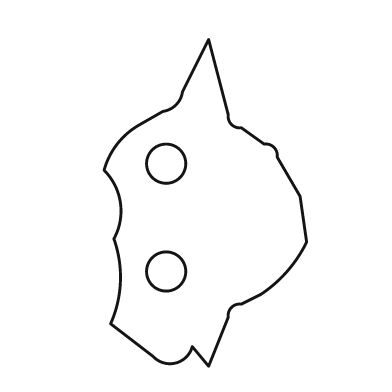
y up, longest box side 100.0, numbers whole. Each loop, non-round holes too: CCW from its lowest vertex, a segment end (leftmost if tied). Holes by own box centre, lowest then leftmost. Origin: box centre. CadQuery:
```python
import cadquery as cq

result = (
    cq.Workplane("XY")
    .moveTo(1.0, -50.0)
    .lineTo(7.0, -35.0)
    .threePointArc((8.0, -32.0), (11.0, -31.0))
    .lineTo(17.0, -28.0)
    .threePointArc((25.0, -21.0), (31.0, -12.0))
    .lineTo(29.0, 2.0)
    .lineTo(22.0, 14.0)
    .threePointArc((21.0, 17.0), (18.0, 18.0))
    .lineTo(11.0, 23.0)
    .threePointArc((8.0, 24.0), (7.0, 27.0))
    .lineTo(1.0, 50.0)
    .lineTo(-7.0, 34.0)
    .threePointArc((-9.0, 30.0), (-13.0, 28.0))
    .lineTo(-20.0, 24.0)
    .threePointArc((-27.0, 18.0), (-31.0, 10.0))
    .threePointArc((-26.0, 0.0), (-28.0, -11.0))
    .threePointArc((-26.0, -24.0), (-29.0, -37.0))
    .lineTo(-16.0, -47.0)
    .threePointArc((-9.0, -49.0), (-4.0, -44.0))
    .close()
    .moveTo(-12.0, -21.0)
    .circle(6.0)
    .moveTo(-12.0, 12.0)
    .circle(6.0)
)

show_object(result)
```